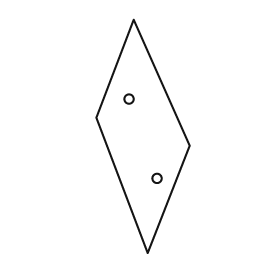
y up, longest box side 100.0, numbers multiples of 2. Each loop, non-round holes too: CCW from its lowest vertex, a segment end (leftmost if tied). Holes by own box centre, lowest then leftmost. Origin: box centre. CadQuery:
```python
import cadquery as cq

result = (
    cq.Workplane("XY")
    .moveTo(2.0, -50.0)
    .lineTo(20.0, -4.0)
    .lineTo(-4.0, 50.0)
    .lineTo(-20.0, 8.0)
    .close()
    .moveTo(6.0, -18.0)
    .circle(2.0)
    .moveTo(-6.0, 16.0)
    .circle(2.0)
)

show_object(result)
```